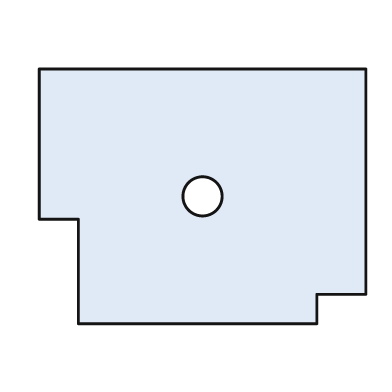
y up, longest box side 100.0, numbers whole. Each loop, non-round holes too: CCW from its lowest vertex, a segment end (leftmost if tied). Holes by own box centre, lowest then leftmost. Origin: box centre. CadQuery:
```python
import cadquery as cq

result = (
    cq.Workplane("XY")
    .moveTo(-38.0, -39.0)
    .lineTo(35.0, -39.0)
    .lineTo(35.0, -30.0)
    .lineTo(50.0, -30.0)
    .lineTo(50.0, 39.0)
    .lineTo(-50.0, 39.0)
    .lineTo(-50.0, -7.0)
    .lineTo(-38.0, -7.0)
    .close()
    .moveTo(0.0, 0.0)
    .circle(6.0)
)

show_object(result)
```